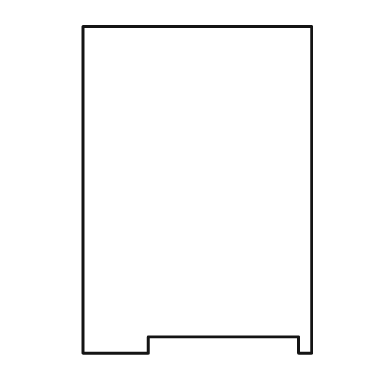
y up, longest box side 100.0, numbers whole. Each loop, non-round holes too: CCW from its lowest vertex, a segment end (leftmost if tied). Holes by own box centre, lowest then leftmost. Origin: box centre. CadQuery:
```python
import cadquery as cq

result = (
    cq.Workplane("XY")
    .moveTo(-35.0, -50.0)
    .lineTo(-15.0, -50.0)
    .lineTo(-15.0, -45.0)
    .lineTo(31.0, -45.0)
    .lineTo(31.0, -50.0)
    .lineTo(35.0, -50.0)
    .lineTo(35.0, 50.0)
    .lineTo(-35.0, 50.0)
    .close()
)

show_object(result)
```